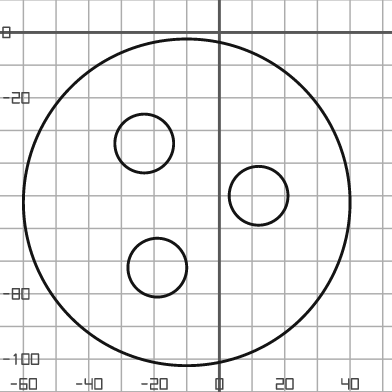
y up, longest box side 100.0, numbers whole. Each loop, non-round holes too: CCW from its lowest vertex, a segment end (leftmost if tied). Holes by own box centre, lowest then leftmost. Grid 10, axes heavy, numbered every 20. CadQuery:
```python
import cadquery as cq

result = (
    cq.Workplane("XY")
    .moveTo(-10.0, -52.0)
    .circle(50.0)
    .moveTo(-19.0, -72.0)
    .circle(9.0)
    .moveTo(12.0, -50.0)
    .circle(9.0)
    .moveTo(-23.0, -34.0)
    .circle(9.0)
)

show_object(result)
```